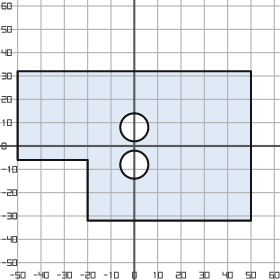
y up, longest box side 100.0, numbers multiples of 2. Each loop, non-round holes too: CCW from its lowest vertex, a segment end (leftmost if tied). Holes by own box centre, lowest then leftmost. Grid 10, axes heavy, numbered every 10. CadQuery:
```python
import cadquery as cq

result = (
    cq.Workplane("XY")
    .moveTo(-20.0, -32.0)
    .lineTo(50.0, -32.0)
    .lineTo(50.0, 32.0)
    .lineTo(-50.0, 32.0)
    .lineTo(-50.0, -6.0)
    .lineTo(-20.0, -6.0)
    .close()
    .moveTo(0.0, -8.0)
    .circle(6.0)
    .moveTo(0.0, 8.0)
    .circle(6.0)
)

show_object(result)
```